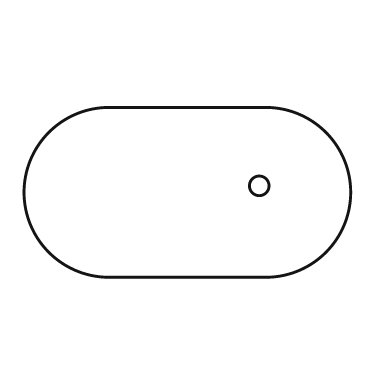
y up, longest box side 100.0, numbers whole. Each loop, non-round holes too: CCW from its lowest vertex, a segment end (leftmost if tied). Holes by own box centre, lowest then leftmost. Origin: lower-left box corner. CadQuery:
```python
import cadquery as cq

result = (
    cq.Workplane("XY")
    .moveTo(26.0, 0.0)
    .lineTo(74.0, 0.0)
    .threePointArc((100.0, 26.0), (74.0, 52.0))
    .lineTo(26.0, 52.0)
    .threePointArc((0.0, 26.0), (26.0, 0.0))
    .close()
    .moveTo(72.0, 28.0)
    .circle(3.0)
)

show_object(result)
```